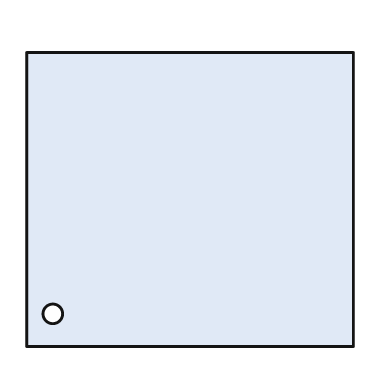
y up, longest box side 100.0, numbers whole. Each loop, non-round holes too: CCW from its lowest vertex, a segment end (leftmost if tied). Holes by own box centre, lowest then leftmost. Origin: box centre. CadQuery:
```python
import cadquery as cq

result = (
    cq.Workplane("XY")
    .moveTo(-50.0, -45.0)
    .lineTo(50.0, -45.0)
    .lineTo(50.0, 45.0)
    .lineTo(-50.0, 45.0)
    .close()
    .moveTo(-42.0, -35.0)
    .circle(3.0)
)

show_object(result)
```